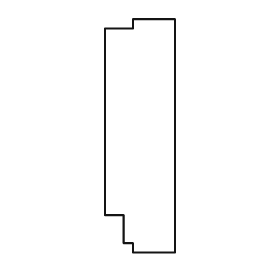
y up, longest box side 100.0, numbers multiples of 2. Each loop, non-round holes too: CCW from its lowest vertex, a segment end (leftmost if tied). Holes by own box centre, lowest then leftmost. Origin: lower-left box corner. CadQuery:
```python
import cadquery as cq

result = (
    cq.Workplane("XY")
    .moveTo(12.0, 0.0)
    .lineTo(30.0, 0.0)
    .lineTo(30.0, 100.0)
    .lineTo(12.0, 100.0)
    .lineTo(12.0, 96.0)
    .lineTo(0.0, 96.0)
    .lineTo(0.0, 16.0)
    .lineTo(8.0, 16.0)
    .lineTo(8.0, 4.0)
    .lineTo(12.0, 4.0)
    .close()
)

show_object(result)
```